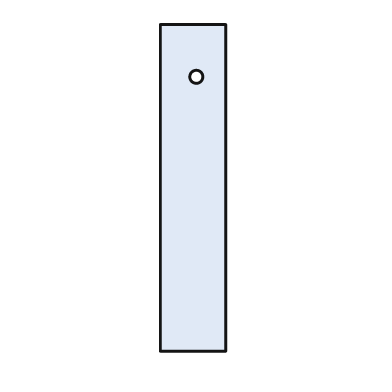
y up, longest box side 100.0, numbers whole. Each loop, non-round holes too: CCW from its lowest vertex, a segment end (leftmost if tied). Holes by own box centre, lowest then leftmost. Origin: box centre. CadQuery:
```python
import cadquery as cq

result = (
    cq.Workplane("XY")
    .moveTo(-10.0, -50.0)
    .lineTo(10.0, -50.0)
    .lineTo(10.0, 50.0)
    .lineTo(-10.0, 50.0)
    .close()
    .moveTo(1.0, 34.0)
    .circle(2.0)
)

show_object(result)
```